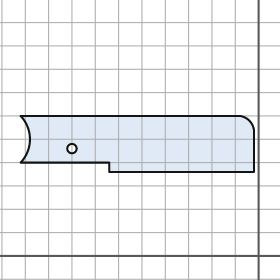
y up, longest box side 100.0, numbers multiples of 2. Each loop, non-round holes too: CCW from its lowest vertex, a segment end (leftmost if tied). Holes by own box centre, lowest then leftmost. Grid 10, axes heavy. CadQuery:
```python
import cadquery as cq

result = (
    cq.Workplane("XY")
    .moveTo(-64.0, 36.0)
    .lineTo(-2.0, 36.0)
    .lineTo(-2.0, 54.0)
    .threePointArc((-4.0, 58.0), (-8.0, 60.0))
    .lineTo(-102.0, 60.0)
    .threePointArc((-98.0, 50.0), (-102.0, 40.0))
    .lineTo(-64.0, 40.0)
    .close()
    .moveTo(-80.0, 46.0)
    .circle(2.0)
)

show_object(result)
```